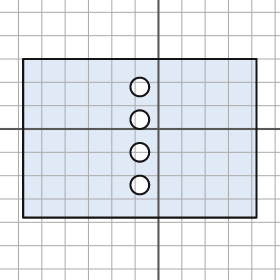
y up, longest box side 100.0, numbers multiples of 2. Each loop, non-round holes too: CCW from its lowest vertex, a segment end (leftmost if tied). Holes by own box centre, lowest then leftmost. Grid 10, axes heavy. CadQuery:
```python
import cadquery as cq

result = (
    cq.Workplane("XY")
    .moveTo(-58.0, -38.0)
    .lineTo(42.0, -38.0)
    .lineTo(42.0, 30.0)
    .lineTo(-58.0, 30.0)
    .close()
    .moveTo(-8.0, -24.0)
    .circle(4.0)
    .moveTo(-8.0, -10.0)
    .circle(4.0)
    .moveTo(-8.0, 4.0)
    .circle(4.0)
    .moveTo(-8.0, 18.0)
    .circle(4.0)
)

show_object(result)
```